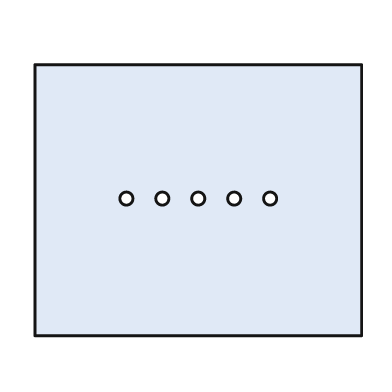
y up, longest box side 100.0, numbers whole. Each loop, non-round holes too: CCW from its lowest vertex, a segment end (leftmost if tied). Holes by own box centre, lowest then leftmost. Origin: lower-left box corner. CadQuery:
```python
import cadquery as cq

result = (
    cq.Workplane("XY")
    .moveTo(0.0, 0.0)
    .lineTo(100.0, 0.0)
    .lineTo(100.0, 83.0)
    .lineTo(0.0, 83.0)
    .close()
    .moveTo(28.0, 42.0)
    .circle(2.0)
    .moveTo(39.0, 42.0)
    .circle(2.0)
    .moveTo(50.0, 42.0)
    .circle(2.0)
    .moveTo(61.0, 42.0)
    .circle(2.0)
    .moveTo(72.0, 42.0)
    .circle(2.0)
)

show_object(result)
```